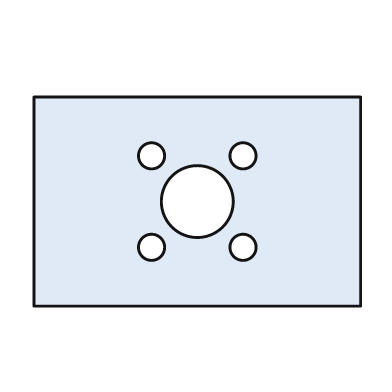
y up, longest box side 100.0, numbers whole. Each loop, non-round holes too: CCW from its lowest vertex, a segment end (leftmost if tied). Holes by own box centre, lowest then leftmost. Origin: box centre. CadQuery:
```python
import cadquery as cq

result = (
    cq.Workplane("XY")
    .moveTo(-50.0, -32.0)
    .lineTo(50.0, -32.0)
    .lineTo(50.0, 32.0)
    .lineTo(-50.0, 32.0)
    .close()
    .moveTo(-14.0, -14.0)
    .circle(4.0)
    .moveTo(14.0, -14.0)
    .circle(4.0)
    .moveTo(0.0, 0.0)
    .circle(11.0)
    .moveTo(-14.0, 14.0)
    .circle(4.0)
    .moveTo(14.0, 14.0)
    .circle(4.0)
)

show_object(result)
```